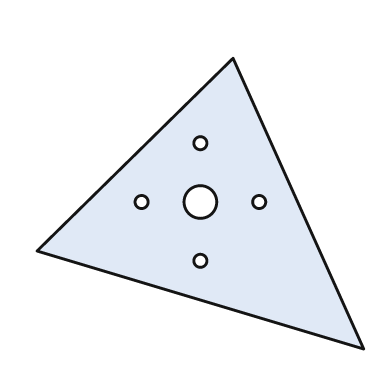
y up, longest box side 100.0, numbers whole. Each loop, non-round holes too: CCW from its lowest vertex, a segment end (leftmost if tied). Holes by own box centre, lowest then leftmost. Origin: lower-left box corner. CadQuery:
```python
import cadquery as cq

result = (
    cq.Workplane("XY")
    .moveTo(100.0, 0.0)
    .lineTo(60.0, 89.0)
    .lineTo(0.0, 30.0)
    .close()
    .moveTo(50.0, 27.0)
    .circle(2.0)
    .moveTo(32.0, 45.0)
    .circle(2.0)
    .moveTo(50.0, 45.0)
    .circle(5.0)
    .moveTo(68.0, 45.0)
    .circle(2.0)
    .moveTo(50.0, 63.0)
    .circle(2.0)
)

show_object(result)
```